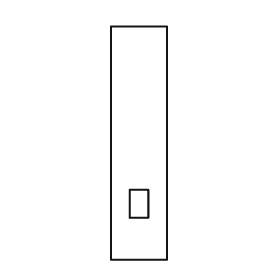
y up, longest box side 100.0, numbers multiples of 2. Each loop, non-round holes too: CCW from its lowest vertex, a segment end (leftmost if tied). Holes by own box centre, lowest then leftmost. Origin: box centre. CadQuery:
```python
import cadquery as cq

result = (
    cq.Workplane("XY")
    .moveTo(-12.0, -50.0)
    .lineTo(12.0, -50.0)
    .lineTo(12.0, 50.0)
    .lineTo(-12.0, 50.0)
    .close()
    .moveTo(-4.0, -32.0)
    .lineTo(4.0, -32.0)
    .lineTo(4.0, -20.0)
    .lineTo(-4.0, -20.0)
    .close()
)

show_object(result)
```